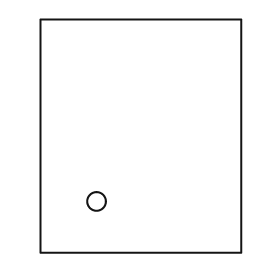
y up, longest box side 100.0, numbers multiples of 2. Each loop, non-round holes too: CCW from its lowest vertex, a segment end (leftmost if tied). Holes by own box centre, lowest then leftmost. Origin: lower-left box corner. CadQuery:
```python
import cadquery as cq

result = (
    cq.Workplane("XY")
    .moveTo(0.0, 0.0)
    .lineTo(86.0, 0.0)
    .lineTo(86.0, 100.0)
    .lineTo(0.0, 100.0)
    .close()
    .moveTo(24.0, 22.0)
    .circle(4.0)
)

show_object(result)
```